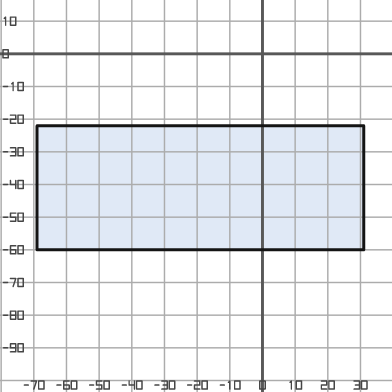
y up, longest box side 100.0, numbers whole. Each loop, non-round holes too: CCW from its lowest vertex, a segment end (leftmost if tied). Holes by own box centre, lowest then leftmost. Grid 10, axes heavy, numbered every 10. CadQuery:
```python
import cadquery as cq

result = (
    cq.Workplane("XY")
    .moveTo(-69.0, -60.0)
    .lineTo(31.0, -60.0)
    .lineTo(31.0, -22.0)
    .lineTo(-69.0, -22.0)
    .close()
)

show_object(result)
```